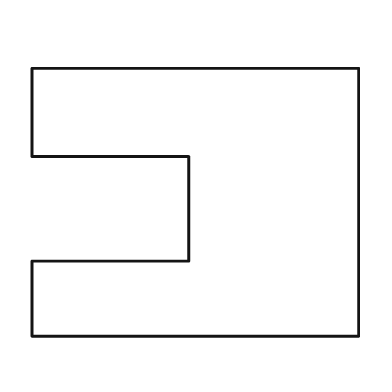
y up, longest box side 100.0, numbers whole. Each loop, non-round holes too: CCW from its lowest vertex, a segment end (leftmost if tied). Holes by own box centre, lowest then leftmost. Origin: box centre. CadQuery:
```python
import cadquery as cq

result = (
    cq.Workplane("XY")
    .moveTo(-50.0, -41.0)
    .lineTo(50.0, -41.0)
    .lineTo(50.0, 41.0)
    .lineTo(-50.0, 41.0)
    .lineTo(-50.0, 14.0)
    .lineTo(-2.0, 14.0)
    .lineTo(-2.0, -18.0)
    .lineTo(-50.0, -18.0)
    .close()
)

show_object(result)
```